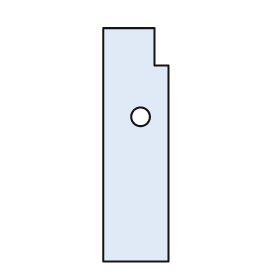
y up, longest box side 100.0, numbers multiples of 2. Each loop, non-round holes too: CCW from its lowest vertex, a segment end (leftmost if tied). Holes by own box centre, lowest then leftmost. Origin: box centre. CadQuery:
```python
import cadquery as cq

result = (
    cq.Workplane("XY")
    .moveTo(-14.0, -50.0)
    .lineTo(14.0, -50.0)
    .lineTo(14.0, 34.0)
    .lineTo(8.0, 34.0)
    .lineTo(8.0, 50.0)
    .lineTo(-14.0, 50.0)
    .close()
    .moveTo(2.0, 12.0)
    .circle(4.0)
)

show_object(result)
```